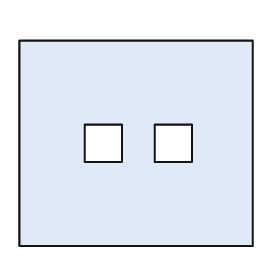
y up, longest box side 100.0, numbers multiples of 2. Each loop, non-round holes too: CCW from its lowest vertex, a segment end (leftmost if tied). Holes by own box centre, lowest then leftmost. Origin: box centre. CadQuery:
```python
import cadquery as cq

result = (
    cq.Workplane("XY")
    .moveTo(-50.0, -44.0)
    .lineTo(50.0, -44.0)
    .lineTo(50.0, 44.0)
    .lineTo(-50.0, 44.0)
    .close()
    .moveTo(-22.0, -8.0)
    .lineTo(-6.0, -8.0)
    .lineTo(-6.0, 8.0)
    .lineTo(-22.0, 8.0)
    .close()
    .moveTo(8.0, -8.0)
    .lineTo(24.0, -8.0)
    .lineTo(24.0, 8.0)
    .lineTo(8.0, 8.0)
    .close()
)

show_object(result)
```